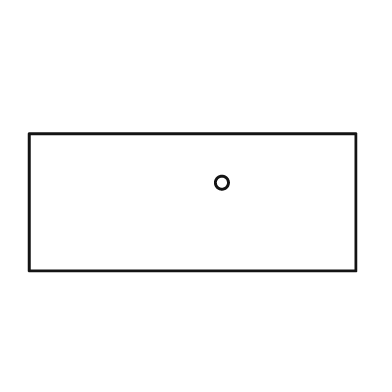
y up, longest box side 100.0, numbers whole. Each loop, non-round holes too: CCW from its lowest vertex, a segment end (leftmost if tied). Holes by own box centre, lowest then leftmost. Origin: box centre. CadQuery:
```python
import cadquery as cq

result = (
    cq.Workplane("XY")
    .moveTo(-50.0, -21.0)
    .lineTo(50.0, -21.0)
    .lineTo(50.0, 21.0)
    .lineTo(-50.0, 21.0)
    .close()
    .moveTo(9.0, 6.0)
    .circle(2.0)
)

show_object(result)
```